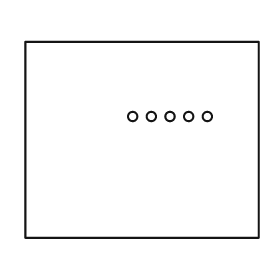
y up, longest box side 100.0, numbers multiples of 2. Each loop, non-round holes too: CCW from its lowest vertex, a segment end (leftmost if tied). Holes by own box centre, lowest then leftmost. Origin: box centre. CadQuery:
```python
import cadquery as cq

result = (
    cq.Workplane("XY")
    .moveTo(-50.0, -42.0)
    .lineTo(50.0, -42.0)
    .lineTo(50.0, 42.0)
    .lineTo(-50.0, 42.0)
    .close()
    .moveTo(-4.0, 10.0)
    .circle(2.0)
    .moveTo(4.0, 10.0)
    .circle(2.0)
    .moveTo(12.0, 10.0)
    .circle(2.0)
    .moveTo(20.0, 10.0)
    .circle(2.0)
    .moveTo(28.0, 10.0)
    .circle(2.0)
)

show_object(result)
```